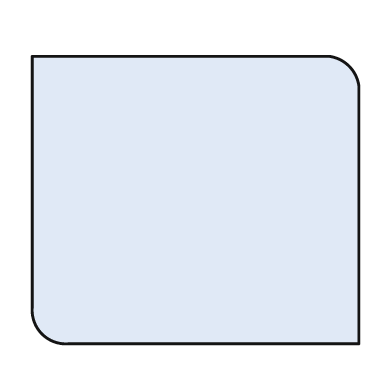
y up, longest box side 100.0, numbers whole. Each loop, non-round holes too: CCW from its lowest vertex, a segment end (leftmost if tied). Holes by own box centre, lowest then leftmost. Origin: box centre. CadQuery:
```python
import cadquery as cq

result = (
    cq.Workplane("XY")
    .moveTo(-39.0, -44.0)
    .lineTo(50.0, -44.0)
    .lineTo(50.0, 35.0)
    .threePointArc((47.0, 41.0), (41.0, 44.0))
    .lineTo(-50.0, 44.0)
    .lineTo(-50.0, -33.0)
    .threePointArc((-47.0, -41.0), (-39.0, -44.0))
    .close()
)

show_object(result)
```